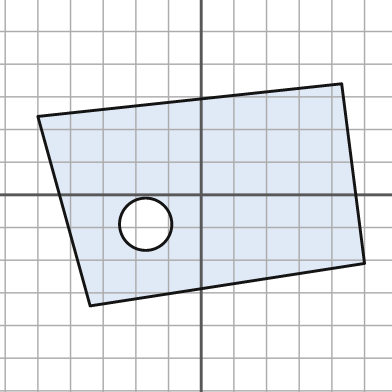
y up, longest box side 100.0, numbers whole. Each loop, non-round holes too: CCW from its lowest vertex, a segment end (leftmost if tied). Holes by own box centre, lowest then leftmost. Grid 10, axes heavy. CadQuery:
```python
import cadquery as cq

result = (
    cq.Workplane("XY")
    .moveTo(-34.0, -34.0)
    .lineTo(50.0, -21.0)
    .lineTo(43.0, 34.0)
    .lineTo(-50.0, 24.0)
    .close()
    .moveTo(-17.0, -9.0)
    .circle(8.0)
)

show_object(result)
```